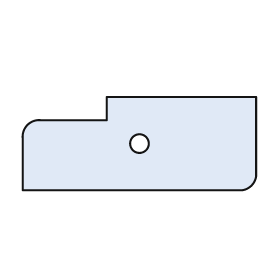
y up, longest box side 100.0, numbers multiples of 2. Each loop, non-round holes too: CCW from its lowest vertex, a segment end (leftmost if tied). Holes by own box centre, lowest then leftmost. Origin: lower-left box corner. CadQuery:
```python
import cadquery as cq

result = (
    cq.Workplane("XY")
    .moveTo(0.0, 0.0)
    .lineTo(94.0, 0.0)
    .threePointArc((98.0, 2.0), (100.0, 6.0))
    .lineTo(100.0, 40.0)
    .lineTo(36.0, 40.0)
    .lineTo(36.0, 30.0)
    .lineTo(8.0, 30.0)
    .threePointArc((2.0, 28.0), (0.0, 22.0))
    .close()
    .moveTo(50.0, 20.0)
    .circle(4.0)
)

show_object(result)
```